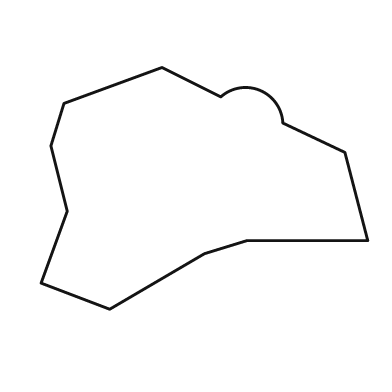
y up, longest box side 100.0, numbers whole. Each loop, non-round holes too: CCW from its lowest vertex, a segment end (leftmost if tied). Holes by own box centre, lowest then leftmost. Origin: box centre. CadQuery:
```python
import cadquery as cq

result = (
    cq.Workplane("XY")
    .moveTo(-29.0, -37.0)
    .lineTo(0.0, -20.0)
    .lineTo(13.0, -16.0)
    .lineTo(50.0, -16.0)
    .lineTo(43.0, 11.0)
    .lineTo(24.0, 20.0)
    .threePointArc((17.0, 30.0), (5.0, 28.0))
    .lineTo(-13.0, 37.0)
    .lineTo(-43.0, 26.0)
    .lineTo(-47.0, 13.0)
    .lineTo(-42.0, -7.0)
    .lineTo(-50.0, -29.0)
    .close()
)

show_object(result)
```